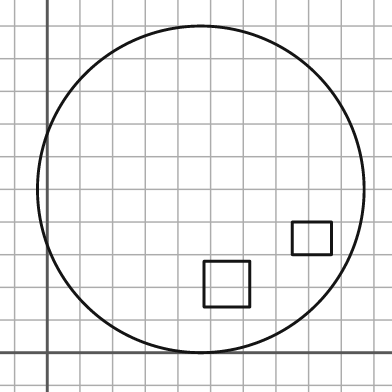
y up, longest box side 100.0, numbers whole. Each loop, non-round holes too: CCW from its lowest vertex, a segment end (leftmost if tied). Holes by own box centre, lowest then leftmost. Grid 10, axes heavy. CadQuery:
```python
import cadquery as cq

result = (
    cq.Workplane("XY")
    .moveTo(47.0, 50.0)
    .circle(50.0)
    .moveTo(48.0, 14.0)
    .lineTo(62.0, 14.0)
    .lineTo(62.0, 28.0)
    .lineTo(48.0, 28.0)
    .close()
    .moveTo(75.0, 30.0)
    .lineTo(87.0, 30.0)
    .lineTo(87.0, 40.0)
    .lineTo(75.0, 40.0)
    .close()
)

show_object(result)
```